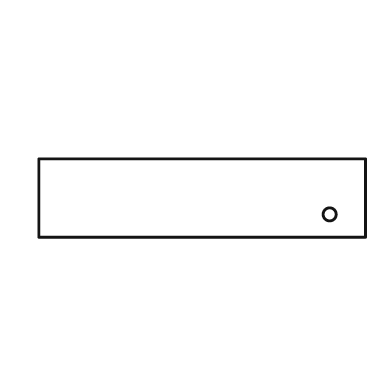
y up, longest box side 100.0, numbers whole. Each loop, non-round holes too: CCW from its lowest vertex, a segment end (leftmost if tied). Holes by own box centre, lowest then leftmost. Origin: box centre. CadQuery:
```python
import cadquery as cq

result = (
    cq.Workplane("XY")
    .moveTo(-50.0, -12.0)
    .lineTo(50.0, -12.0)
    .lineTo(50.0, 12.0)
    .lineTo(-50.0, 12.0)
    .close()
    .moveTo(39.0, -5.0)
    .circle(2.0)
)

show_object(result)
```